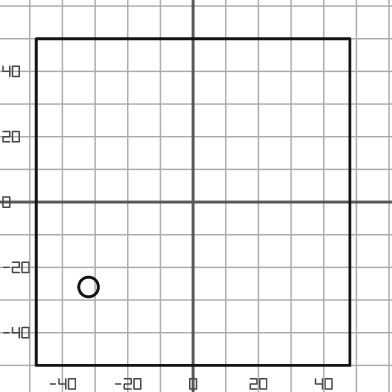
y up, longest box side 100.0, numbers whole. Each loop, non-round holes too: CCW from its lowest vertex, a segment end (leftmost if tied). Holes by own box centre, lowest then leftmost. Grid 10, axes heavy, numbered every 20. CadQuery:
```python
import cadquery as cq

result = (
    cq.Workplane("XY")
    .moveTo(-48.0, -50.0)
    .lineTo(48.0, -50.0)
    .lineTo(48.0, 50.0)
    .lineTo(-48.0, 50.0)
    .close()
    .moveTo(-32.0, -26.0)
    .circle(3.0)
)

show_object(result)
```